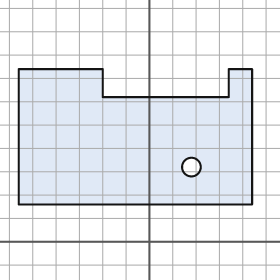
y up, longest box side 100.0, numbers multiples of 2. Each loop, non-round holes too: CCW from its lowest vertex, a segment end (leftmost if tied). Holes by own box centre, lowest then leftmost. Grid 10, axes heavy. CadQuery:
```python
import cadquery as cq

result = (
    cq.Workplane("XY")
    .moveTo(-56.0, 16.0)
    .lineTo(44.0, 16.0)
    .lineTo(44.0, 74.0)
    .lineTo(34.0, 74.0)
    .lineTo(34.0, 62.0)
    .lineTo(-20.0, 62.0)
    .lineTo(-20.0, 74.0)
    .lineTo(-56.0, 74.0)
    .close()
    .moveTo(18.0, 32.0)
    .circle(4.0)
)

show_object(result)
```